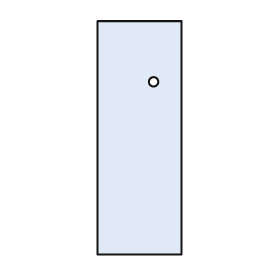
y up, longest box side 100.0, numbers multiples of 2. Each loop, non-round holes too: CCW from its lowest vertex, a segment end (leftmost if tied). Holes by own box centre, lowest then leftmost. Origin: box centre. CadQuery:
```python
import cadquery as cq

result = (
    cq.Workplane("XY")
    .moveTo(-18.0, -50.0)
    .lineTo(18.0, -50.0)
    .lineTo(18.0, 50.0)
    .lineTo(-18.0, 50.0)
    .close()
    .moveTo(6.0, 24.0)
    .circle(2.0)
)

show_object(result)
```